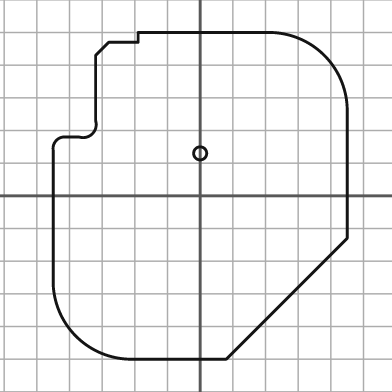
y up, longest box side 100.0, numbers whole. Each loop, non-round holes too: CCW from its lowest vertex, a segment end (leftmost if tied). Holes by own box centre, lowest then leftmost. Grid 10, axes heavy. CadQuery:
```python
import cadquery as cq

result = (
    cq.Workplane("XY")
    .moveTo(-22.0, -50.0)
    .lineTo(8.0, -50.0)
    .lineTo(45.0, -13.0)
    .lineTo(45.0, 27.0)
    .threePointArc((38.0, 43.0), (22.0, 50.0))
    .lineTo(-19.0, 50.0)
    .lineTo(-19.0, 47.0)
    .lineTo(-28.0, 47.0)
    .lineTo(-32.0, 43.0)
    .lineTo(-32.0, 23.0)
    .threePointArc((-33.0, 19.0), (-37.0, 18.0))
    .lineTo(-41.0, 18.0)
    .threePointArc((-44.0, 17.0), (-45.0, 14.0))
    .lineTo(-45.0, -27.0)
    .threePointArc((-38.0, -43.0), (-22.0, -50.0))
    .close()
    .moveTo(0.0, 13.0)
    .circle(2.0)
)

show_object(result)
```